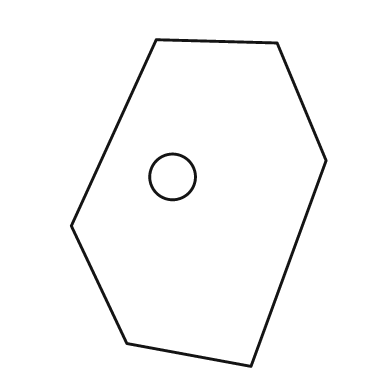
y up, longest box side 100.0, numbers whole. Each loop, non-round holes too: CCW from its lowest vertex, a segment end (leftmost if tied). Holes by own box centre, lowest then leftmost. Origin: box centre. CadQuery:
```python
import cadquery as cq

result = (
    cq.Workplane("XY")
    .moveTo(16.0, -50.0)
    .lineTo(39.0, 13.0)
    .lineTo(24.0, 49.0)
    .lineTo(-13.0, 50.0)
    .lineTo(-39.0, -7.0)
    .lineTo(-22.0, -43.0)
    .close()
    .moveTo(-8.0, 8.0)
    .circle(7.0)
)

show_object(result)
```